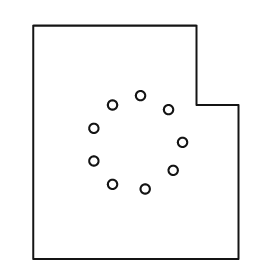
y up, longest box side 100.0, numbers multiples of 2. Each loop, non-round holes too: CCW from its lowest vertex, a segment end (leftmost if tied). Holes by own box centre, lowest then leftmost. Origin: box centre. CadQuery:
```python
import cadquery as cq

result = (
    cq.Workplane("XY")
    .moveTo(-44.0, -50.0)
    .lineTo(44.0, -50.0)
    .lineTo(44.0, 16.0)
    .lineTo(26.0, 16.0)
    .lineTo(26.0, 50.0)
    .lineTo(-44.0, 50.0)
    .close()
    .moveTo(4.0, -20.0)
    .circle(2.0)
    .moveTo(-10.0, -18.0)
    .circle(2.0)
    .moveTo(16.0, -12.0)
    .circle(2.0)
    .moveTo(-18.0, -8.0)
    .circle(2.0)
    .moveTo(20.0, 0.0)
    .circle(2.0)
    .moveTo(-18.0, 6.0)
    .circle(2.0)
    .moveTo(14.0, 14.0)
    .circle(2.0)
    .moveTo(-10.0, 16.0)
    .circle(2.0)
    .moveTo(2.0, 20.0)
    .circle(2.0)
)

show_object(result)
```